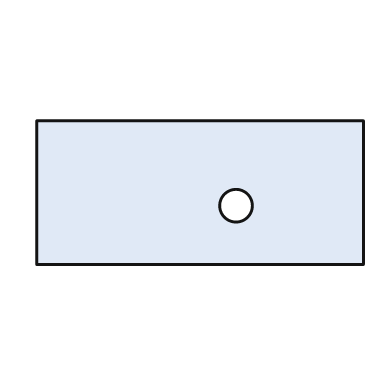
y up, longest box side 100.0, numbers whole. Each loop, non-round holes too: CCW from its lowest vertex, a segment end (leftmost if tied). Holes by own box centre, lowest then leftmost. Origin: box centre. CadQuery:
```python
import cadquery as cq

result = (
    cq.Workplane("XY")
    .moveTo(-50.0, -22.0)
    .lineTo(50.0, -22.0)
    .lineTo(50.0, 22.0)
    .lineTo(-50.0, 22.0)
    .close()
    .moveTo(11.0, -4.0)
    .circle(5.0)
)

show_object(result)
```